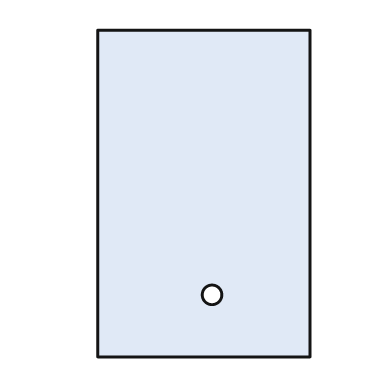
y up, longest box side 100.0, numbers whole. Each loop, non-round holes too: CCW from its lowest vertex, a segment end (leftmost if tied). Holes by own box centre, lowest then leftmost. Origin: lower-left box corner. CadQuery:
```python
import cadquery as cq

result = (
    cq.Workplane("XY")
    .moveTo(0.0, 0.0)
    .lineTo(65.0, 0.0)
    .lineTo(65.0, 100.0)
    .lineTo(0.0, 100.0)
    .close()
    .moveTo(35.0, 19.0)
    .circle(3.0)
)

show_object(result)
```